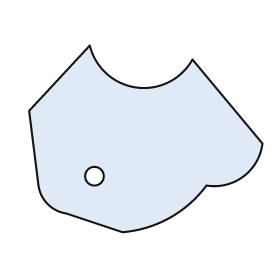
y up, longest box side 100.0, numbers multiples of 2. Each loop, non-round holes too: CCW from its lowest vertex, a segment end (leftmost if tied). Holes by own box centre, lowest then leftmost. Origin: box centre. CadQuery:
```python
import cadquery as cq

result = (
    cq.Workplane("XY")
    .moveTo(-10.0, -40.0)
    .threePointArc((10.0, -34.0), (26.0, -20.0))
    .threePointArc((42.0, -16.0), (50.0, -2.0))
    .lineTo(20.0, 34.0)
    .threePointArc((-4.0, 22.0), (-24.0, 40.0))
    .lineTo(-50.0, 12.0)
    .lineTo(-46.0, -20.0)
    .threePointArc((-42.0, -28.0), (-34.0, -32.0))
    .close()
    .moveTo(-22.0, -16.0)
    .circle(4.0)
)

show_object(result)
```